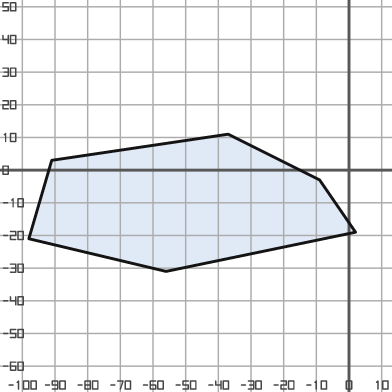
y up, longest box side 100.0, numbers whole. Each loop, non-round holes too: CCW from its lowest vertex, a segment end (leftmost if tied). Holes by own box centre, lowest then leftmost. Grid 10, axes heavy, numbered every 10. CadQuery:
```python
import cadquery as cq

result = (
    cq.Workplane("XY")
    .moveTo(-56.0, -31.0)
    .lineTo(2.0, -19.0)
    .lineTo(-9.0, -3.0)
    .lineTo(-37.0, 11.0)
    .lineTo(-91.0, 3.0)
    .lineTo(-98.0, -21.0)
    .close()
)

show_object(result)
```